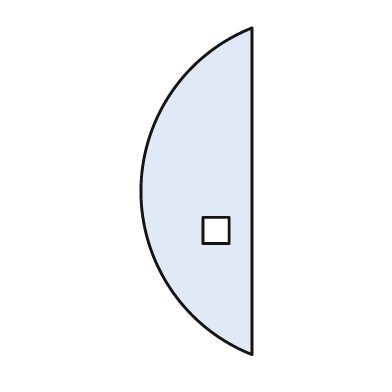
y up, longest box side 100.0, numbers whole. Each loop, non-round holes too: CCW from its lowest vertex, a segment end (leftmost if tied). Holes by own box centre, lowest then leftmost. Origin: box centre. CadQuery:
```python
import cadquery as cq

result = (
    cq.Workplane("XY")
    .moveTo(17.0, -50.0)
    .lineTo(17.0, 50.0)
    .threePointArc((-17.0, 0.0), (17.0, -50.0))
    .close()
    .moveTo(2.0, -16.0)
    .lineTo(10.0, -16.0)
    .lineTo(10.0, -8.0)
    .lineTo(2.0, -8.0)
    .close()
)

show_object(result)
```